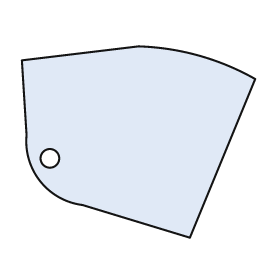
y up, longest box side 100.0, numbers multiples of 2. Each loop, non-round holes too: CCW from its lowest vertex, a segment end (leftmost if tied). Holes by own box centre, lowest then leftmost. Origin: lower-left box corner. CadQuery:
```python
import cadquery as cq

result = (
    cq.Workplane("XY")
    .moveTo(72.0, 0.0)
    .lineTo(100.0, 68.0)
    .threePointArc((76.0, 78.0), (50.0, 82.0))
    .lineTo(0.0, 76.0)
    .lineTo(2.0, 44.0)
    .threePointArc((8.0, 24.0), (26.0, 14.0))
    .close()
    .moveTo(12.0, 34.0)
    .circle(4.0)
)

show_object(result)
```